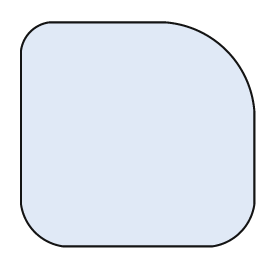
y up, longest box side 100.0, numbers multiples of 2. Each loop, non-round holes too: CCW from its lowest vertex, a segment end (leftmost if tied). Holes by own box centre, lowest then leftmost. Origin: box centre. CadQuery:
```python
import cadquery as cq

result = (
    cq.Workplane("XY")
    .moveTo(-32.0, -48.0)
    .lineTo(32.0, -48.0)
    .threePointArc((44.0, -42.0), (50.0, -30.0))
    .lineTo(50.0, 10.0)
    .threePointArc((38.0, 36.0), (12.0, 48.0))
    .lineTo(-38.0, 48.0)
    .threePointArc((-46.0, 44.0), (-50.0, 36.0))
    .lineTo(-50.0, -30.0)
    .threePointArc((-44.0, -42.0), (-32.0, -48.0))
    .close()
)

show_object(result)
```